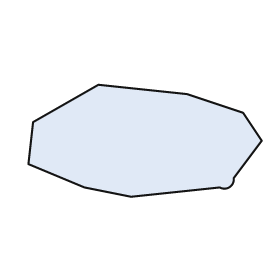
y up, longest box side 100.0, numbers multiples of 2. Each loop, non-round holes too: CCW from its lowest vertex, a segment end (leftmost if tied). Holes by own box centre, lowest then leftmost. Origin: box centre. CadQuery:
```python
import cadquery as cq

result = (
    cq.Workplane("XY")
    .moveTo(-6.0, -24.0)
    .lineTo(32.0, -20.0)
    .threePointArc((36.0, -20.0), (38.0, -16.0))
    .lineTo(50.0, 0.0)
    .lineTo(42.0, 12.0)
    .lineTo(18.0, 20.0)
    .lineTo(-20.0, 24.0)
    .lineTo(-48.0, 8.0)
    .lineTo(-50.0, -10.0)
    .lineTo(-26.0, -20.0)
    .close()
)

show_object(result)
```